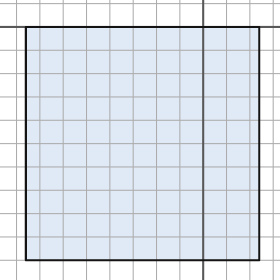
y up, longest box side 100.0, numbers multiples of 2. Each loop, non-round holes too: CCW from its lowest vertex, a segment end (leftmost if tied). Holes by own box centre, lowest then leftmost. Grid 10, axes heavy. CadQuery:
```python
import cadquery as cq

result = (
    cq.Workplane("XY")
    .moveTo(-76.0, -100.0)
    .lineTo(24.0, -100.0)
    .lineTo(24.0, 0.0)
    .lineTo(-76.0, 0.0)
    .close()
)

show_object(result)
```